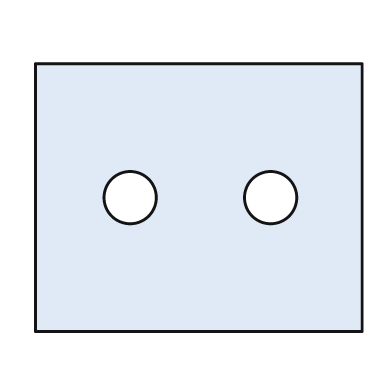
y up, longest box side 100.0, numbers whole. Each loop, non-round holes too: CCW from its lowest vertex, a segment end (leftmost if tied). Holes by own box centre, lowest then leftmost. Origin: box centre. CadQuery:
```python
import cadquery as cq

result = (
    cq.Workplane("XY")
    .moveTo(-50.0, -41.0)
    .lineTo(50.0, -41.0)
    .lineTo(50.0, 41.0)
    .lineTo(-50.0, 41.0)
    .close()
    .moveTo(-21.0, 0.0)
    .circle(8.0)
    .moveTo(22.0, 0.0)
    .circle(8.0)
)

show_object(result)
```